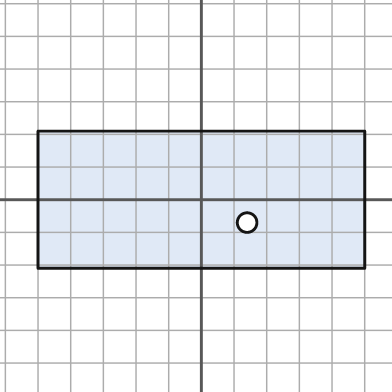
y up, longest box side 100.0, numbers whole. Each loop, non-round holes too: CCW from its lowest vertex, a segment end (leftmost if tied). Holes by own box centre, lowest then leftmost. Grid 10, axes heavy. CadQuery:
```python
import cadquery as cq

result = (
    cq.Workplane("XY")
    .moveTo(-50.0, -21.0)
    .lineTo(50.0, -21.0)
    .lineTo(50.0, 21.0)
    .lineTo(-50.0, 21.0)
    .close()
    .moveTo(14.0, -7.0)
    .circle(3.0)
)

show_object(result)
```